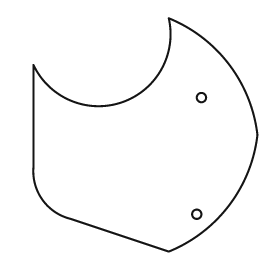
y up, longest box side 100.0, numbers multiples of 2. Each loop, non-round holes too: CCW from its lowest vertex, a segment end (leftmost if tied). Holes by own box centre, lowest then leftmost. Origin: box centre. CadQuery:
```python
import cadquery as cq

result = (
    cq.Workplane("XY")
    .moveTo(10.0, -50.0)
    .threePointArc((36.0, -30.0), (48.0, 0.0))
    .threePointArc((36.0, 30.0), (10.0, 50.0))
    .threePointArc((-10.0, 14.0), (-48.0, 30.0))
    .lineTo(-48.0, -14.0)
    .threePointArc((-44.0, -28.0), (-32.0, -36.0))
    .close()
    .moveTo(22.0, -34.0)
    .circle(2.0)
    .moveTo(24.0, 16.0)
    .circle(2.0)
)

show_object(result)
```